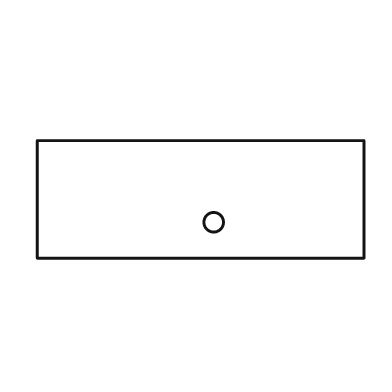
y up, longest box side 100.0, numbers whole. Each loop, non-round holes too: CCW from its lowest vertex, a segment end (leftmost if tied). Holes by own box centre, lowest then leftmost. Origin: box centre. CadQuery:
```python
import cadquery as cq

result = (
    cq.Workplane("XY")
    .moveTo(-50.0, -18.0)
    .lineTo(50.0, -18.0)
    .lineTo(50.0, 18.0)
    .lineTo(-50.0, 18.0)
    .close()
    .moveTo(4.0, -7.0)
    .circle(3.0)
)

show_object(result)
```